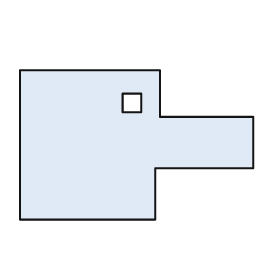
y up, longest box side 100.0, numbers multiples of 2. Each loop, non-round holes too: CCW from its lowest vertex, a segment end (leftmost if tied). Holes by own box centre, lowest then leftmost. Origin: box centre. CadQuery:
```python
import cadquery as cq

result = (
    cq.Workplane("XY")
    .moveTo(-50.0, -32.0)
    .lineTo(8.0, -32.0)
    .lineTo(8.0, -10.0)
    .lineTo(50.0, -10.0)
    .lineTo(50.0, 12.0)
    .lineTo(10.0, 12.0)
    .lineTo(10.0, 32.0)
    .lineTo(-50.0, 32.0)
    .close()
    .moveTo(-6.0, 14.0)
    .lineTo(2.0, 14.0)
    .lineTo(2.0, 22.0)
    .lineTo(-6.0, 22.0)
    .close()
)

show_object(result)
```